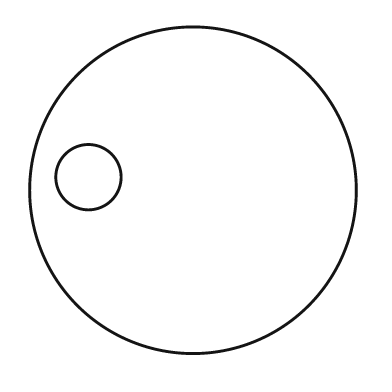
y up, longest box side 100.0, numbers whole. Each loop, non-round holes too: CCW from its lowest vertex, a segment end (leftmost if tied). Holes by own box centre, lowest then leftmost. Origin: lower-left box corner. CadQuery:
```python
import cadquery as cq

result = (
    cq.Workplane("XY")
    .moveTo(50.0, 50.0)
    .circle(50.0)
    .moveTo(18.0, 54.0)
    .circle(10.0)
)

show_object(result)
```